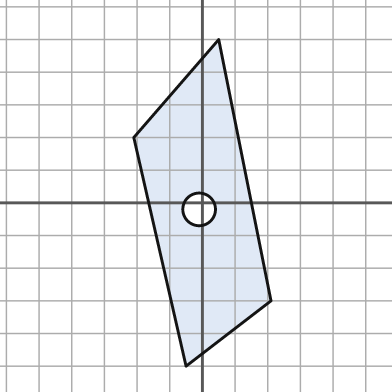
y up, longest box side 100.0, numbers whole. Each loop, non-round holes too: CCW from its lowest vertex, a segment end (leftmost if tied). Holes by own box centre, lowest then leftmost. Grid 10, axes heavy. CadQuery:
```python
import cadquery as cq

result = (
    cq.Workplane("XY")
    .moveTo(-5.0, -50.0)
    .lineTo(21.0, -30.0)
    .lineTo(5.0, 50.0)
    .lineTo(-21.0, 20.0)
    .close()
    .moveTo(-1.0, -2.0)
    .circle(5.0)
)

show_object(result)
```